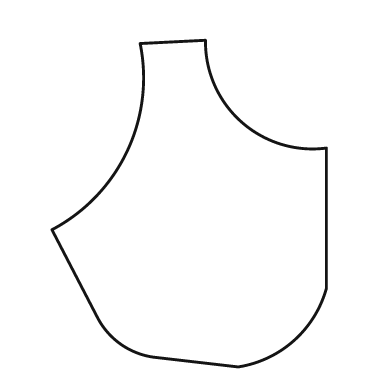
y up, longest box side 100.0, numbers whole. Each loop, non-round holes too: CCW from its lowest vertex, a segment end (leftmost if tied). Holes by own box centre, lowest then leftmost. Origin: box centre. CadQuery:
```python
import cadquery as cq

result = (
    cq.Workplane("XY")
    .moveTo(15.0, -50.0)
    .threePointArc((32.0, -42.0), (42.0, -26.0))
    .lineTo(42.0, 17.0)
    .threePointArc((16.0, 25.0), (5.0, 50.0))
    .lineTo(-15.0, 49.0)
    .threePointArc((-19.0, 16.0), (-42.0, -8.0))
    .lineTo(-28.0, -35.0)
    .threePointArc((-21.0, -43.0), (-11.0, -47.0))
    .close()
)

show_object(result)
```